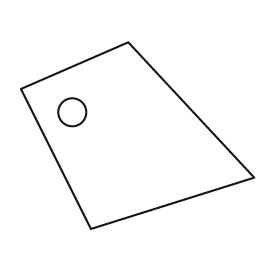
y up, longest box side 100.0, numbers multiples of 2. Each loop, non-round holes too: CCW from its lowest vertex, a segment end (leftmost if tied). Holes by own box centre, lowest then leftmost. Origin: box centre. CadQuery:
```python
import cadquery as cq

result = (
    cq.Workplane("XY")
    .moveTo(-20.0, -40.0)
    .lineTo(50.0, -18.0)
    .lineTo(-4.0, 40.0)
    .lineTo(-50.0, 20.0)
    .close()
    .moveTo(-28.0, 10.0)
    .circle(6.0)
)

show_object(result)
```